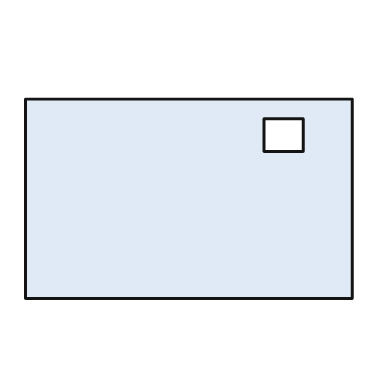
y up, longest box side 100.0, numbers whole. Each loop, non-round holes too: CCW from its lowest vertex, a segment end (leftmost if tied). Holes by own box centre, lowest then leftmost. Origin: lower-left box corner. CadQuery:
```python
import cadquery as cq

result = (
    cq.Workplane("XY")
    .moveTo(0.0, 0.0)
    .lineTo(100.0, 0.0)
    .lineTo(100.0, 61.0)
    .lineTo(0.0, 61.0)
    .close()
    .moveTo(73.0, 45.0)
    .lineTo(85.0, 45.0)
    .lineTo(85.0, 55.0)
    .lineTo(73.0, 55.0)
    .close()
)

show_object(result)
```